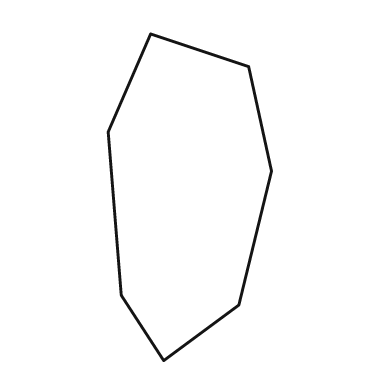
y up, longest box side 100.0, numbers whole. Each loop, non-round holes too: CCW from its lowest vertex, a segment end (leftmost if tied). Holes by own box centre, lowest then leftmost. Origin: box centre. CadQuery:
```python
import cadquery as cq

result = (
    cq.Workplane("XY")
    .moveTo(-8.0, -50.0)
    .lineTo(15.0, -33.0)
    .lineTo(25.0, 8.0)
    .lineTo(18.0, 40.0)
    .lineTo(-12.0, 50.0)
    .lineTo(-25.0, 20.0)
    .lineTo(-21.0, -30.0)
    .close()
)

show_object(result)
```